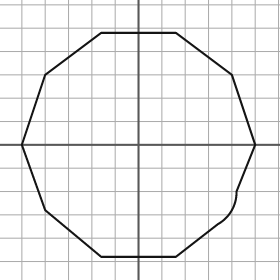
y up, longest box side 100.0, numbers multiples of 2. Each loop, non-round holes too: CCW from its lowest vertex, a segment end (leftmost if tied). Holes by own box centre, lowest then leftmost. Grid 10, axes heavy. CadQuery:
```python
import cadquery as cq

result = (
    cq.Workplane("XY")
    .moveTo(-16.0, -48.0)
    .lineTo(16.0, -48.0)
    .lineTo(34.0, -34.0)
    .threePointArc((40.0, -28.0), (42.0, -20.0))
    .lineTo(50.0, 0.0)
    .lineTo(40.0, 30.0)
    .lineTo(16.0, 48.0)
    .lineTo(-16.0, 48.0)
    .lineTo(-40.0, 30.0)
    .lineTo(-50.0, 0.0)
    .lineTo(-40.0, -28.0)
    .close()
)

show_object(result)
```